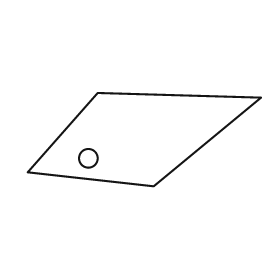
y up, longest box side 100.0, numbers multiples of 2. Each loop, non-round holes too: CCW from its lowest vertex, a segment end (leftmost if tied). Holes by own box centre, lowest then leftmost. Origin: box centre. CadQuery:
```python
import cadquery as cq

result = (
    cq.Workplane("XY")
    .moveTo(4.0, -20.0)
    .lineTo(50.0, 18.0)
    .lineTo(-20.0, 20.0)
    .lineTo(-50.0, -14.0)
    .close()
    .moveTo(-24.0, -8.0)
    .circle(4.0)
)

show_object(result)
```